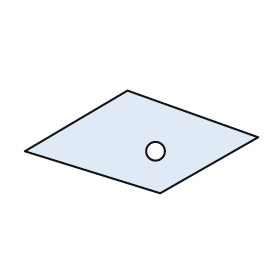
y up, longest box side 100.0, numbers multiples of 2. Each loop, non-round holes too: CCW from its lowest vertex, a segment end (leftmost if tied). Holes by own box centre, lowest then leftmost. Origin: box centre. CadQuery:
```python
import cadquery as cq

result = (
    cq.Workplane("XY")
    .moveTo(8.0, -22.0)
    .lineTo(50.0, 2.0)
    .lineTo(-6.0, 22.0)
    .lineTo(-50.0, -4.0)
    .close()
    .moveTo(6.0, -4.0)
    .circle(4.0)
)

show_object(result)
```